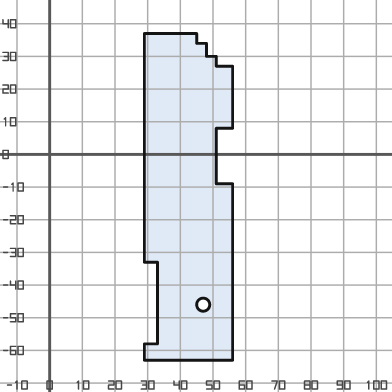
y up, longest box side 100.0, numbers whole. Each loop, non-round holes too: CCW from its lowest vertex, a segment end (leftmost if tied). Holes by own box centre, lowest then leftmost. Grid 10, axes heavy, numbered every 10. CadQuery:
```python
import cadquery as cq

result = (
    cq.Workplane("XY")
    .moveTo(29.0, -63.0)
    .lineTo(56.0, -63.0)
    .lineTo(56.0, -9.0)
    .lineTo(51.0, -9.0)
    .lineTo(51.0, 8.0)
    .lineTo(56.0, 8.0)
    .lineTo(56.0, 27.0)
    .lineTo(51.0, 27.0)
    .lineTo(51.0, 30.0)
    .lineTo(48.0, 30.0)
    .lineTo(48.0, 34.0)
    .lineTo(45.0, 34.0)
    .lineTo(45.0, 37.0)
    .lineTo(29.0, 37.0)
    .lineTo(29.0, -33.0)
    .lineTo(33.0, -33.0)
    .lineTo(33.0, -58.0)
    .lineTo(29.0, -58.0)
    .close()
    .moveTo(47.0, -46.0)
    .circle(2.0)
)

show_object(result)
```